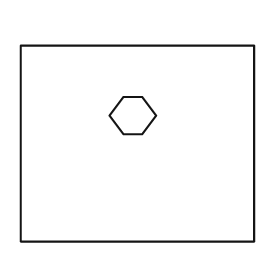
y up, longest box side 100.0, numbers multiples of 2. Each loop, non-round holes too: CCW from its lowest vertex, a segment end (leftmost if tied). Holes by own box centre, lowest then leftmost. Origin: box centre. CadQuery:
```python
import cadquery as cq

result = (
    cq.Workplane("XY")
    .moveTo(-50.0, -42.0)
    .lineTo(50.0, -42.0)
    .lineTo(50.0, 42.0)
    .lineTo(-50.0, 42.0)
    .close()
    .moveTo(-6.0, 4.0)
    .lineTo(2.0, 4.0)
    .lineTo(8.0, 12.0)
    .lineTo(2.0, 20.0)
    .lineTo(-6.0, 20.0)
    .lineTo(-12.0, 12.0)
    .close()
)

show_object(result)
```